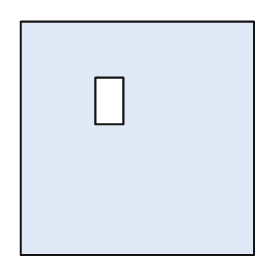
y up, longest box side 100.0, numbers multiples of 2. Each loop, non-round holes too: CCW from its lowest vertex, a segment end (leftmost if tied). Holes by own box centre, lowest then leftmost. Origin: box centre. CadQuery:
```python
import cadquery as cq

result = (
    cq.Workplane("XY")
    .moveTo(-50.0, -50.0)
    .lineTo(50.0, -50.0)
    .lineTo(50.0, 50.0)
    .lineTo(-50.0, 50.0)
    .close()
    .moveTo(-18.0, 6.0)
    .lineTo(-6.0, 6.0)
    .lineTo(-6.0, 26.0)
    .lineTo(-18.0, 26.0)
    .close()
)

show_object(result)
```